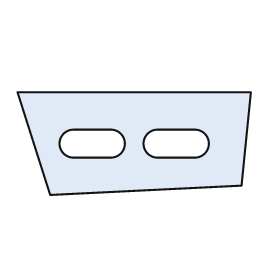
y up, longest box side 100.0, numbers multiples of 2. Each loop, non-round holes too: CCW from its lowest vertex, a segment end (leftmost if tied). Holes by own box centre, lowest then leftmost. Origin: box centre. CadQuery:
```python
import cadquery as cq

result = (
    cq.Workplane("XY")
    .moveTo(-36.0, -22.0)
    .lineTo(46.0, -18.0)
    .lineTo(50.0, 22.0)
    .lineTo(-50.0, 22.0)
    .close()
    .moveTo(-26.0, -6.0)
    .lineTo(-10.0, -6.0)
    .threePointArc((-4.0, 0.0), (-10.0, 6.0))
    .lineTo(-26.0, 6.0)
    .threePointArc((-32.0, 0.0), (-26.0, -6.0))
    .close()
    .moveTo(10.0, -6.0)
    .lineTo(26.0, -6.0)
    .threePointArc((32.0, 0.0), (26.0, 6.0))
    .lineTo(10.0, 6.0)
    .threePointArc((4.0, 0.0), (10.0, -6.0))
    .close()
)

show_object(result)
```